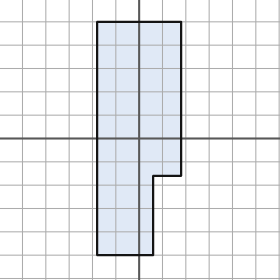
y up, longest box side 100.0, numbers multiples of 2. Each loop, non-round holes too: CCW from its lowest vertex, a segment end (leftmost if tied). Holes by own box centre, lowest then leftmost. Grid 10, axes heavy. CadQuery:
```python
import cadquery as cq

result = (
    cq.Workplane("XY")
    .moveTo(-18.0, -50.0)
    .lineTo(6.0, -50.0)
    .lineTo(6.0, -16.0)
    .lineTo(18.0, -16.0)
    .lineTo(18.0, 50.0)
    .lineTo(-18.0, 50.0)
    .close()
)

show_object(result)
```